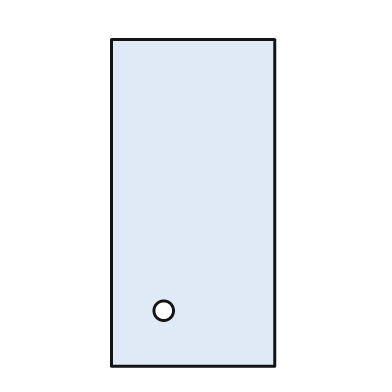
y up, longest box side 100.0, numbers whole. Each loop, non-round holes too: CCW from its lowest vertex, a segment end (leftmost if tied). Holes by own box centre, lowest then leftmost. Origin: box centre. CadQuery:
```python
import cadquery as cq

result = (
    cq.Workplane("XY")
    .moveTo(-25.0, -50.0)
    .lineTo(25.0, -50.0)
    .lineTo(25.0, 50.0)
    .lineTo(-25.0, 50.0)
    .close()
    .moveTo(-9.0, -33.0)
    .circle(3.0)
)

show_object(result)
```